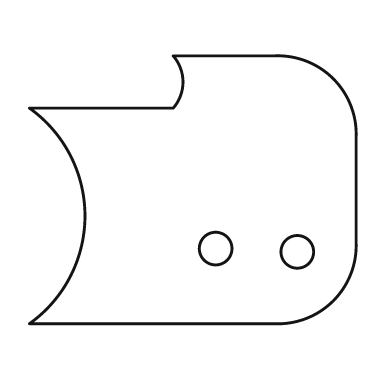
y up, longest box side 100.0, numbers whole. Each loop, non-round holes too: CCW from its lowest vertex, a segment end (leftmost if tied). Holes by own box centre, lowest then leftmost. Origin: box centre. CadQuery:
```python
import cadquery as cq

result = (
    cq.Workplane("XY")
    .moveTo(-50.0, -41.0)
    .lineTo(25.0, -41.0)
    .threePointArc((43.0, -34.0), (50.0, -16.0))
    .lineTo(50.0, 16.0)
    .threePointArc((43.0, 34.0), (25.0, 41.0))
    .lineTo(-6.0, 41.0)
    .threePointArc((-3.0, 33.0), (-6.0, 25.0))
    .lineTo(-50.0, 25.0)
    .threePointArc((-33.0, -8.0), (-50.0, -41.0))
    .close()
    .moveTo(32.0, -19.0)
    .circle(5.0)
    .moveTo(7.0, -18.0)
    .circle(5.0)
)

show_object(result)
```